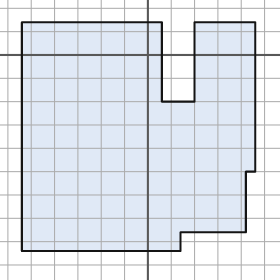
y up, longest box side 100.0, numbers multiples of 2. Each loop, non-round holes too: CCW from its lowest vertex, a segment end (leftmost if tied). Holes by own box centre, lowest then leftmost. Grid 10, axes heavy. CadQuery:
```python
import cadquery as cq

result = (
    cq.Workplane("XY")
    .moveTo(-54.0, -84.0)
    .lineTo(14.0, -84.0)
    .lineTo(14.0, -76.0)
    .lineTo(42.0, -76.0)
    .lineTo(42.0, -50.0)
    .lineTo(46.0, -50.0)
    .lineTo(46.0, 14.0)
    .lineTo(20.0, 14.0)
    .lineTo(20.0, -20.0)
    .lineTo(6.0, -20.0)
    .lineTo(6.0, 14.0)
    .lineTo(-54.0, 14.0)
    .close()
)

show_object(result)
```